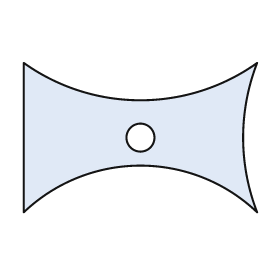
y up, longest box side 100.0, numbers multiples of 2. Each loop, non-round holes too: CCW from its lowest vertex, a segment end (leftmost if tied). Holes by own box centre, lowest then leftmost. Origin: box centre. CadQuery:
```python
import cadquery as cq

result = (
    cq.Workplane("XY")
    .moveTo(-50.0, -32.0)
    .threePointArc((0.0, -12.0), (50.0, -32.0))
    .threePointArc((44.0, 0.0), (50.0, 32.0))
    .threePointArc((0.0, 16.0), (-50.0, 32.0))
    .close()
    .moveTo(0.0, 0.0)
    .circle(6.0)
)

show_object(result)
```